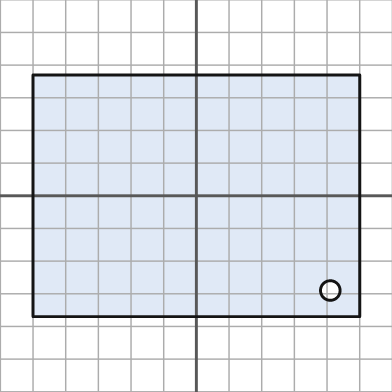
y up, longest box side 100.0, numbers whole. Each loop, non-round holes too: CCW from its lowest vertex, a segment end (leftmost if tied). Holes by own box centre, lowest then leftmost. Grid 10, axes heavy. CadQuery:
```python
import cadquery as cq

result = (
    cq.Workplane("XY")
    .moveTo(-50.0, -37.0)
    .lineTo(50.0, -37.0)
    .lineTo(50.0, 37.0)
    .lineTo(-50.0, 37.0)
    .close()
    .moveTo(41.0, -29.0)
    .circle(3.0)
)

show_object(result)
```